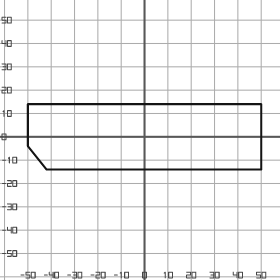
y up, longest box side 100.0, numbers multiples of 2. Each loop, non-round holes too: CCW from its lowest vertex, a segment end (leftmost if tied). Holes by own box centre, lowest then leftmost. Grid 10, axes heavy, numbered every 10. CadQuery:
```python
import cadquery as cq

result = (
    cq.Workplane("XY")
    .moveTo(-42.0, -14.0)
    .lineTo(50.0, -14.0)
    .lineTo(50.0, 14.0)
    .lineTo(-50.0, 14.0)
    .lineTo(-50.0, -4.0)
    .close()
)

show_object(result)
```